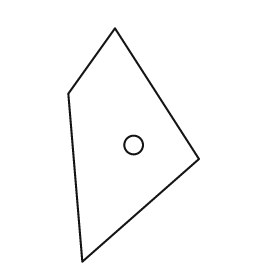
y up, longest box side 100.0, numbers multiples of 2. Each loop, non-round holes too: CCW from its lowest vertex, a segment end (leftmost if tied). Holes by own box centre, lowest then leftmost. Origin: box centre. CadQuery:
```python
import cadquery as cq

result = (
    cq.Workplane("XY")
    .moveTo(-22.0, -50.0)
    .lineTo(28.0, -6.0)
    .lineTo(-8.0, 50.0)
    .lineTo(-28.0, 22.0)
    .close()
    .moveTo(0.0, 0.0)
    .circle(4.0)
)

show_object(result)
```